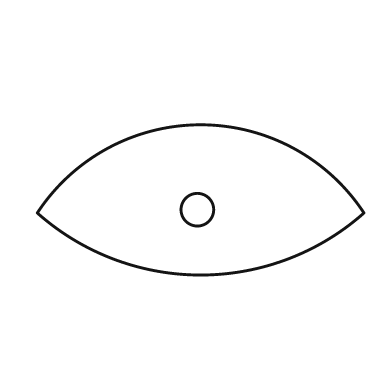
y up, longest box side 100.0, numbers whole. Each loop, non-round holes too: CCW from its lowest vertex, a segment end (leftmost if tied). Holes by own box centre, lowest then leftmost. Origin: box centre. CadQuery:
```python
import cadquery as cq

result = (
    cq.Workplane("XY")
    .moveTo(-50.0, -4.0)
    .threePointArc((0.0, -23.0), (50.0, -4.0))
    .threePointArc((0.0, 23.0), (-50.0, -4.0))
    .close()
    .moveTo(-1.0, -3.0)
    .circle(5.0)
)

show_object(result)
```